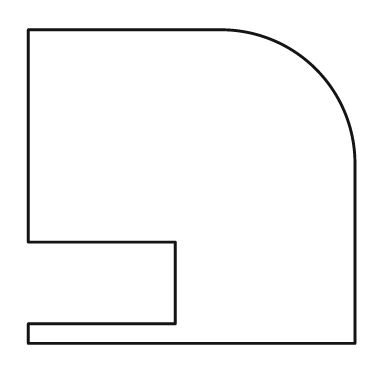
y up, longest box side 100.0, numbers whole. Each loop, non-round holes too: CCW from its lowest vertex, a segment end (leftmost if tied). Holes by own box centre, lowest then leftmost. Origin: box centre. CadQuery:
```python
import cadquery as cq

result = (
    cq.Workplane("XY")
    .moveTo(-50.0, -48.0)
    .lineTo(50.0, -48.0)
    .lineTo(50.0, 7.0)
    .threePointArc((38.0, 36.0), (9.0, 48.0))
    .lineTo(-50.0, 48.0)
    .lineTo(-50.0, -17.0)
    .lineTo(-5.0, -17.0)
    .lineTo(-5.0, -42.0)
    .lineTo(-50.0, -42.0)
    .close()
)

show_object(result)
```